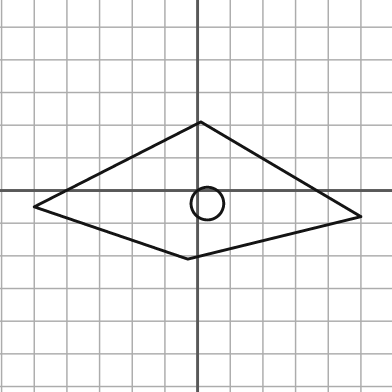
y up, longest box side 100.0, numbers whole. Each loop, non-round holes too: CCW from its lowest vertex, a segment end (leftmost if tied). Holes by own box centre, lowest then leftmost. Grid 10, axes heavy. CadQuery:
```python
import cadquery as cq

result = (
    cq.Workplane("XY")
    .moveTo(-3.0, -21.0)
    .lineTo(50.0, -8.0)
    .lineTo(1.0, 21.0)
    .lineTo(-50.0, -5.0)
    .close()
    .moveTo(3.0, -4.0)
    .circle(5.0)
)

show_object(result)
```